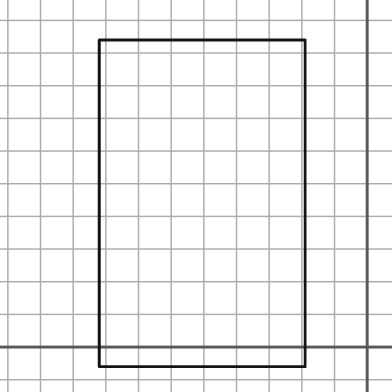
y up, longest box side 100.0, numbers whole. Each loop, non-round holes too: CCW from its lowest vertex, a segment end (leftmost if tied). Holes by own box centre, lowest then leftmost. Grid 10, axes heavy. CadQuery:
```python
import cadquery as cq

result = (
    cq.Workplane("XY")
    .moveTo(-82.0, -6.0)
    .lineTo(-19.0, -6.0)
    .lineTo(-19.0, 94.0)
    .lineTo(-82.0, 94.0)
    .close()
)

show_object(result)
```